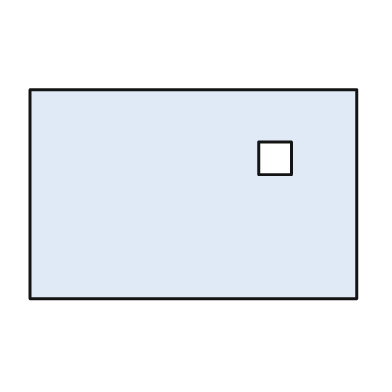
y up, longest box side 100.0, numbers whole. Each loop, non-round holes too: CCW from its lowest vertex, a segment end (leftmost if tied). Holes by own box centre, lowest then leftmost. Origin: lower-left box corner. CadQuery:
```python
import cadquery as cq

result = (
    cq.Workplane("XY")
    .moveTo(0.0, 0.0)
    .lineTo(100.0, 0.0)
    .lineTo(100.0, 64.0)
    .lineTo(0.0, 64.0)
    .close()
    .moveTo(70.0, 38.0)
    .lineTo(80.0, 38.0)
    .lineTo(80.0, 48.0)
    .lineTo(70.0, 48.0)
    .close()
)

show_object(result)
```